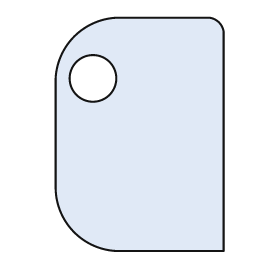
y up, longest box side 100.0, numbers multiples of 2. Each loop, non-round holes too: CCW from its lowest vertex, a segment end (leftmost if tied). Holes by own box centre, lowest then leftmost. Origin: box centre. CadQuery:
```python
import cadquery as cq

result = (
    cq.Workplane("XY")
    .moveTo(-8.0, -50.0)
    .lineTo(36.0, -50.0)
    .lineTo(36.0, 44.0)
    .threePointArc((34.0, 48.0), (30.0, 50.0))
    .lineTo(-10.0, 50.0)
    .threePointArc((-28.0, 42.0), (-36.0, 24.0))
    .lineTo(-36.0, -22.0)
    .threePointArc((-28.0, -42.0), (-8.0, -50.0))
    .close()
    .moveTo(-20.0, 24.0)
    .circle(10.0)
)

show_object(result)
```